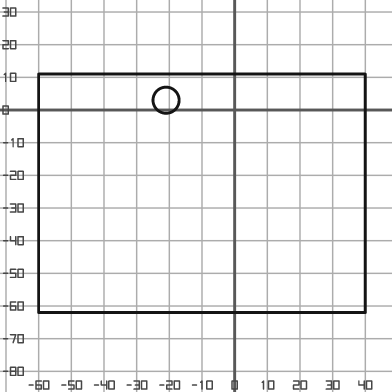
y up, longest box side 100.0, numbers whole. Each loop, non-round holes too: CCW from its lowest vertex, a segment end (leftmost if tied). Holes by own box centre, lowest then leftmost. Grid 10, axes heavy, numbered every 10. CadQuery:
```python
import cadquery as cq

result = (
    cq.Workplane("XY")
    .moveTo(-60.0, -62.0)
    .lineTo(40.0, -62.0)
    .lineTo(40.0, 11.0)
    .lineTo(-60.0, 11.0)
    .close()
    .moveTo(-21.0, 3.0)
    .circle(4.0)
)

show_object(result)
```